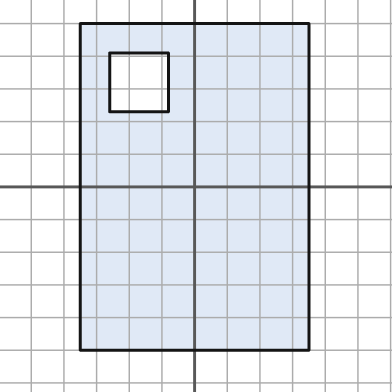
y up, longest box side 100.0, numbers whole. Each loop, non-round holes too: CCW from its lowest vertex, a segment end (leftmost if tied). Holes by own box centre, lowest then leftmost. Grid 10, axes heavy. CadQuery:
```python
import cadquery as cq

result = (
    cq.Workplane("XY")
    .moveTo(-35.0, -50.0)
    .lineTo(35.0, -50.0)
    .lineTo(35.0, 50.0)
    .lineTo(-35.0, 50.0)
    .close()
    .moveTo(-26.0, 23.0)
    .lineTo(-8.0, 23.0)
    .lineTo(-8.0, 41.0)
    .lineTo(-26.0, 41.0)
    .close()
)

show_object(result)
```